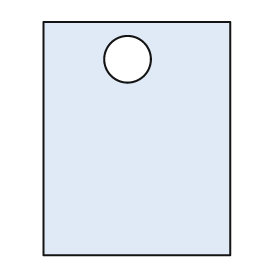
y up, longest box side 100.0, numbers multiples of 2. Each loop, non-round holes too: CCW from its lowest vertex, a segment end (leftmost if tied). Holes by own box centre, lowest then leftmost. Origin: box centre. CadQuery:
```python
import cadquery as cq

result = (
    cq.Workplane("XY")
    .moveTo(-40.0, -50.0)
    .lineTo(40.0, -50.0)
    .lineTo(40.0, 50.0)
    .lineTo(-40.0, 50.0)
    .close()
    .moveTo(-4.0, 34.0)
    .circle(10.0)
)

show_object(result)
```